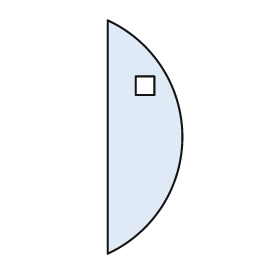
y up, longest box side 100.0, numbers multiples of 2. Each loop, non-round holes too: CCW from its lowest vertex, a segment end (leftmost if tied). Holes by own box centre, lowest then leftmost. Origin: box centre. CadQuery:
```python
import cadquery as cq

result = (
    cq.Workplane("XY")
    .moveTo(-16.0, -50.0)
    .threePointArc((16.0, 0.0), (-16.0, 50.0))
    .close()
    .moveTo(-4.0, 18.0)
    .lineTo(4.0, 18.0)
    .lineTo(4.0, 26.0)
    .lineTo(-4.0, 26.0)
    .close()
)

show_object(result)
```